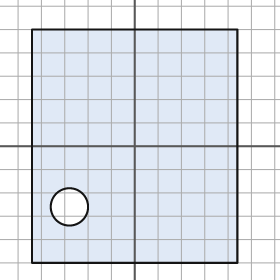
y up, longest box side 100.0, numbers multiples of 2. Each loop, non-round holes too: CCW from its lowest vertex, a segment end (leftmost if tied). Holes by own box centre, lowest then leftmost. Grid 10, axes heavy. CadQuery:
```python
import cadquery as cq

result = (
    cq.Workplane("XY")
    .moveTo(-44.0, -50.0)
    .lineTo(44.0, -50.0)
    .lineTo(44.0, 50.0)
    .lineTo(-44.0, 50.0)
    .close()
    .moveTo(-28.0, -26.0)
    .circle(8.0)
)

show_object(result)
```